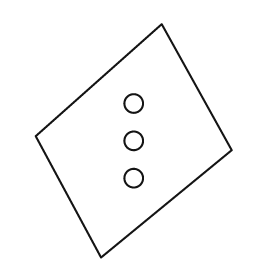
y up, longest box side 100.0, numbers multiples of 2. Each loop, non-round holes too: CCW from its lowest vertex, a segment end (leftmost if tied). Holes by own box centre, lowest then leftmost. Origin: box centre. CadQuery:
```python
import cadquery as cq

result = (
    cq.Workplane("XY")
    .moveTo(-14.0, -50.0)
    .lineTo(42.0, -4.0)
    .lineTo(12.0, 50.0)
    .lineTo(-42.0, 2.0)
    .close()
    .moveTo(0.0, -16.0)
    .circle(4.0)
    .moveTo(0.0, 0.0)
    .circle(4.0)
    .moveTo(0.0, 16.0)
    .circle(4.0)
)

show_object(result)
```